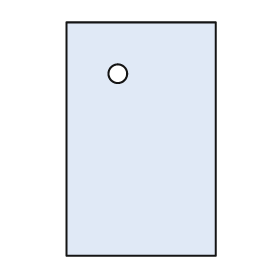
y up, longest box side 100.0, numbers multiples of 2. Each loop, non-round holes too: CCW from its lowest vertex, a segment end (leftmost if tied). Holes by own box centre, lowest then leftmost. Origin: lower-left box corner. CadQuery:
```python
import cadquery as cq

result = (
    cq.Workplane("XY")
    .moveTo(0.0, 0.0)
    .lineTo(64.0, 0.0)
    .lineTo(64.0, 100.0)
    .lineTo(0.0, 100.0)
    .close()
    .moveTo(22.0, 78.0)
    .circle(4.0)
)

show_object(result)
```